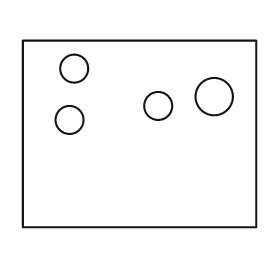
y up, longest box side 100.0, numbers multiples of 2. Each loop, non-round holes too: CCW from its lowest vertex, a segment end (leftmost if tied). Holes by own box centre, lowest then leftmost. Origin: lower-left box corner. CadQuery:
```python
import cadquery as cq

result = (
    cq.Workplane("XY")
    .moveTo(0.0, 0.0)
    .lineTo(100.0, 0.0)
    .lineTo(100.0, 80.0)
    .lineTo(0.0, 80.0)
    .close()
    .moveTo(20.0, 46.0)
    .circle(6.0)
    .moveTo(58.0, 52.0)
    .circle(6.0)
    .moveTo(82.0, 56.0)
    .circle(8.0)
    .moveTo(22.0, 68.0)
    .circle(6.0)
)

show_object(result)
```